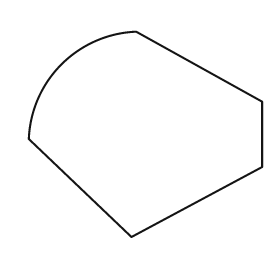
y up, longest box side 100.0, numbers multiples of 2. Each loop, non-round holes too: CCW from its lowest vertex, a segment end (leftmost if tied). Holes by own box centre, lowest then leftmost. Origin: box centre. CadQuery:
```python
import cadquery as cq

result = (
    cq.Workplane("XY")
    .moveTo(-6.0, -44.0)
    .lineTo(50.0, -14.0)
    .lineTo(50.0, 14.0)
    .lineTo(-4.0, 44.0)
    .threePointArc((-36.0, 30.0), (-50.0, -2.0))
    .close()
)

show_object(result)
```